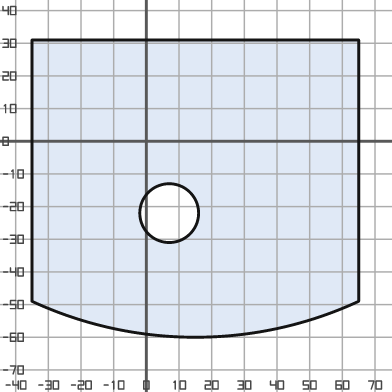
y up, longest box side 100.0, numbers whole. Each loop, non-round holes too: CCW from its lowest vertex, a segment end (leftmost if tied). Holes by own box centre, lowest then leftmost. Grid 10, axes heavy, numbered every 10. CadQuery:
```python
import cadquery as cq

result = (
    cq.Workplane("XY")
    .moveTo(-35.0, -49.0)
    .threePointArc((15.0, -60.0), (65.0, -49.0))
    .lineTo(65.0, 31.0)
    .lineTo(-35.0, 31.0)
    .close()
    .moveTo(7.0, -22.0)
    .circle(9.0)
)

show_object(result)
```